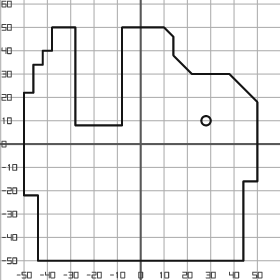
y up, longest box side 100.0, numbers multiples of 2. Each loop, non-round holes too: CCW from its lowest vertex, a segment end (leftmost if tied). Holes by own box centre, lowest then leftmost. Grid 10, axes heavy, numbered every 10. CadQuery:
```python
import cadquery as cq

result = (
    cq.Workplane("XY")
    .moveTo(-44.0, -50.0)
    .lineTo(44.0, -50.0)
    .lineTo(44.0, -16.0)
    .lineTo(50.0, -16.0)
    .lineTo(50.0, 18.0)
    .lineTo(38.0, 30.0)
    .lineTo(22.0, 30.0)
    .lineTo(14.0, 38.0)
    .lineTo(14.0, 46.0)
    .lineTo(10.0, 50.0)
    .lineTo(-8.0, 50.0)
    .lineTo(-8.0, 8.0)
    .lineTo(-28.0, 8.0)
    .lineTo(-28.0, 50.0)
    .lineTo(-38.0, 50.0)
    .lineTo(-38.0, 40.0)
    .lineTo(-42.0, 40.0)
    .lineTo(-42.0, 34.0)
    .lineTo(-46.0, 34.0)
    .lineTo(-46.0, 22.0)
    .lineTo(-50.0, 22.0)
    .lineTo(-50.0, -22.0)
    .lineTo(-44.0, -22.0)
    .close()
    .moveTo(28.0, 10.0)
    .circle(2.0)
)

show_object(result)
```